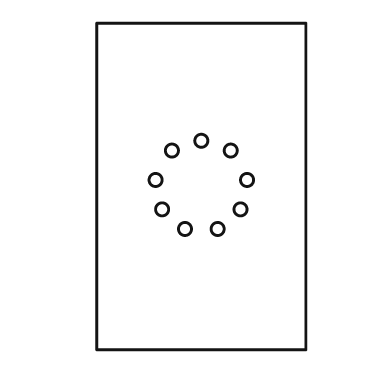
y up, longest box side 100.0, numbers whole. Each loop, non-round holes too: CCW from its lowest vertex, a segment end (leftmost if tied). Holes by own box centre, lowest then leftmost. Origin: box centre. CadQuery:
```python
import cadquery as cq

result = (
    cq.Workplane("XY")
    .moveTo(-32.0, -50.0)
    .lineTo(32.0, -50.0)
    .lineTo(32.0, 50.0)
    .lineTo(-32.0, 50.0)
    .close()
    .moveTo(-5.0, -13.0)
    .circle(2.0)
    .moveTo(5.0, -13.0)
    .circle(2.0)
    .moveTo(-12.0, -7.0)
    .circle(2.0)
    .moveTo(12.0, -7.0)
    .circle(2.0)
    .moveTo(-14.0, 2.0)
    .circle(2.0)
    .moveTo(14.0, 2.0)
    .circle(2.0)
    .moveTo(-9.0, 11.0)
    .circle(2.0)
    .moveTo(9.0, 11.0)
    .circle(2.0)
    .moveTo(0.0, 14.0)
    .circle(2.0)
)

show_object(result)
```